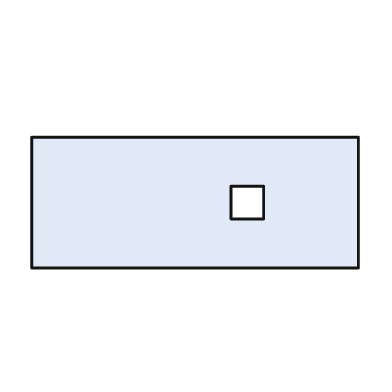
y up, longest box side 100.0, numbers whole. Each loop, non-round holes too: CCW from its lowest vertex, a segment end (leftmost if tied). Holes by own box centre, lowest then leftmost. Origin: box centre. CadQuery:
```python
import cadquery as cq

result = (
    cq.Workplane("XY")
    .moveTo(-50.0, -20.0)
    .lineTo(50.0, -20.0)
    .lineTo(50.0, 20.0)
    .lineTo(-50.0, 20.0)
    .close()
    .moveTo(11.0, -5.0)
    .lineTo(21.0, -5.0)
    .lineTo(21.0, 5.0)
    .lineTo(11.0, 5.0)
    .close()
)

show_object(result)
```